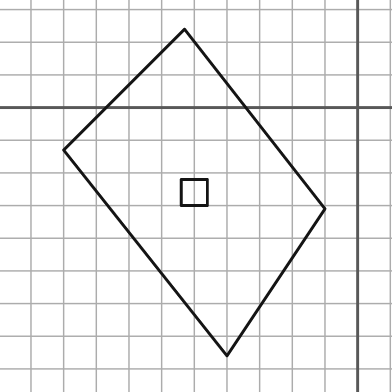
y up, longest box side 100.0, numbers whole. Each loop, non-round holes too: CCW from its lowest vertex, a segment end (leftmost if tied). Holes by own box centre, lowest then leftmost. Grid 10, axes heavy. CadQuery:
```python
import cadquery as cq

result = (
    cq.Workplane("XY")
    .moveTo(-40.0, -76.0)
    .lineTo(-10.0, -31.0)
    .lineTo(-53.0, 24.0)
    .lineTo(-90.0, -13.0)
    .close()
    .moveTo(-54.0, -30.0)
    .lineTo(-46.0, -30.0)
    .lineTo(-46.0, -22.0)
    .lineTo(-54.0, -22.0)
    .close()
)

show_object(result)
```